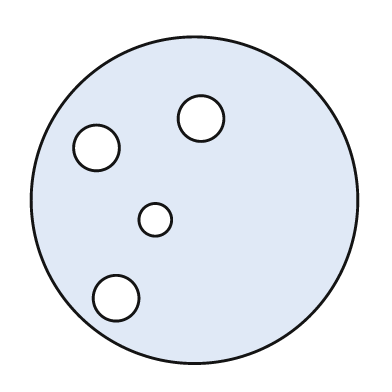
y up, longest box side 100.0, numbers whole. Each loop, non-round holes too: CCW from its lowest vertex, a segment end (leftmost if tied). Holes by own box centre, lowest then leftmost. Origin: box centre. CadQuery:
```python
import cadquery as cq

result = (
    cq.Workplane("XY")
    .moveTo(0.0, 0.0)
    .circle(50.0)
    .moveTo(-24.0, -30.0)
    .circle(7.0)
    .moveTo(-12.0, -6.0)
    .circle(5.0)
    .moveTo(-30.0, 16.0)
    .circle(7.0)
    .moveTo(2.0, 25.0)
    .circle(7.0)
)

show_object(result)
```